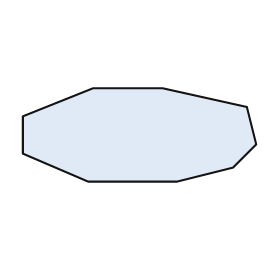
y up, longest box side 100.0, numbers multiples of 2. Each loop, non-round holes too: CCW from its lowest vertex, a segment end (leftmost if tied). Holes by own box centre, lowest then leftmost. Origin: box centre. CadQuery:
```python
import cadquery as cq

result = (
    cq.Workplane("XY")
    .moveTo(-22.0, -20.0)
    .lineTo(16.0, -20.0)
    .lineTo(40.0, -14.0)
    .lineTo(50.0, -4.0)
    .lineTo(46.0, 12.0)
    .lineTo(10.0, 20.0)
    .lineTo(-20.0, 20.0)
    .lineTo(-50.0, 8.0)
    .lineTo(-50.0, -8.0)
    .close()
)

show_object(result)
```